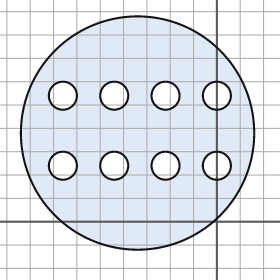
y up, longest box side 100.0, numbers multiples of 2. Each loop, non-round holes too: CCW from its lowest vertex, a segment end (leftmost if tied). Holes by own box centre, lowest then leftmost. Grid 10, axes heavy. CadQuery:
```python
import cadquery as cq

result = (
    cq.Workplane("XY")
    .moveTo(-34.0, 38.0)
    .circle(50.0)
    .moveTo(-66.0, 24.0)
    .circle(6.0)
    .moveTo(-44.0, 24.0)
    .circle(6.0)
    .moveTo(-22.0, 24.0)
    .circle(6.0)
    .moveTo(0.0, 24.0)
    .circle(6.0)
    .moveTo(-66.0, 54.0)
    .circle(6.0)
    .moveTo(-44.0, 54.0)
    .circle(6.0)
    .moveTo(-22.0, 54.0)
    .circle(6.0)
    .moveTo(0.0, 54.0)
    .circle(6.0)
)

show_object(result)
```